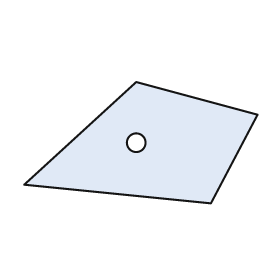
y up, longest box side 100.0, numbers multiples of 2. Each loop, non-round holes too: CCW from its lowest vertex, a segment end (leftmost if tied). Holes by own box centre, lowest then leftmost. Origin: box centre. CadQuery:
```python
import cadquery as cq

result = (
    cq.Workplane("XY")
    .moveTo(30.0, -26.0)
    .lineTo(50.0, 12.0)
    .lineTo(-2.0, 26.0)
    .lineTo(-50.0, -18.0)
    .close()
    .moveTo(-2.0, 0.0)
    .circle(4.0)
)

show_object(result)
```